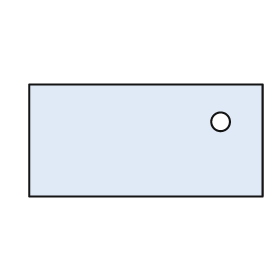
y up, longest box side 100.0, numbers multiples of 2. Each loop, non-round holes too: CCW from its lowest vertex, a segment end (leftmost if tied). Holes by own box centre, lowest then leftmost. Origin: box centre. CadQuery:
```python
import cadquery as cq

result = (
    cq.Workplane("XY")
    .moveTo(-50.0, -24.0)
    .lineTo(50.0, -24.0)
    .lineTo(50.0, 24.0)
    .lineTo(-50.0, 24.0)
    .close()
    .moveTo(32.0, 8.0)
    .circle(4.0)
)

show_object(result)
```